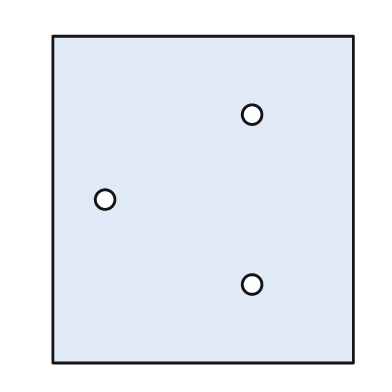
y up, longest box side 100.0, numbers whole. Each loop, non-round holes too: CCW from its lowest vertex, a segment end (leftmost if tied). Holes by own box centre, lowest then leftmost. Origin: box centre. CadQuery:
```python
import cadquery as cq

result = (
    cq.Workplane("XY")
    .moveTo(-46.0, -50.0)
    .lineTo(46.0, -50.0)
    .lineTo(46.0, 50.0)
    .lineTo(-46.0, 50.0)
    .close()
    .moveTo(15.0, -26.0)
    .circle(3.0)
    .moveTo(-30.0, 0.0)
    .circle(3.0)
    .moveTo(15.0, 26.0)
    .circle(3.0)
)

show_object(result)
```